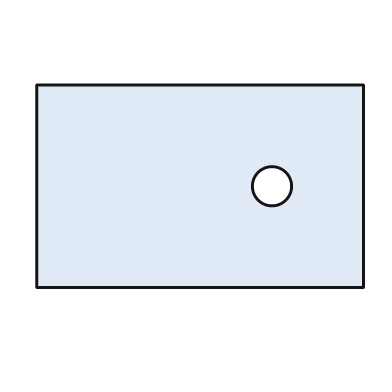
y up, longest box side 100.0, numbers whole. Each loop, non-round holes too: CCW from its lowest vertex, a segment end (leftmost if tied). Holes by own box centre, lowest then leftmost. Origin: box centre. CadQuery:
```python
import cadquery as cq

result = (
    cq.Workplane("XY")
    .moveTo(-50.0, -31.0)
    .lineTo(50.0, -31.0)
    .lineTo(50.0, 31.0)
    .lineTo(-50.0, 31.0)
    .close()
    .moveTo(22.0, 0.0)
    .circle(6.0)
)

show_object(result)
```